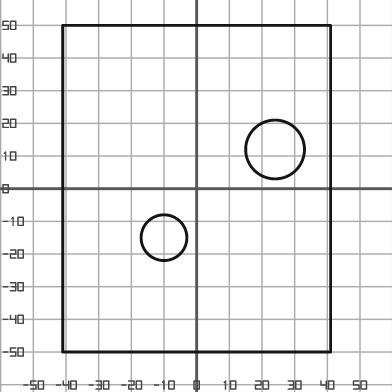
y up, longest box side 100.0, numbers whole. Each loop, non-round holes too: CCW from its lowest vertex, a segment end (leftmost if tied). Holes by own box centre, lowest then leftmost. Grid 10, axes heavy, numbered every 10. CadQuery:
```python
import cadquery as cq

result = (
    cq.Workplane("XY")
    .moveTo(-41.0, -50.0)
    .lineTo(41.0, -50.0)
    .lineTo(41.0, 50.0)
    .lineTo(-41.0, 50.0)
    .close()
    .moveTo(-10.0, -15.0)
    .circle(7.0)
    .moveTo(24.0, 12.0)
    .circle(9.0)
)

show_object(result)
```